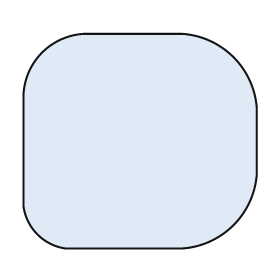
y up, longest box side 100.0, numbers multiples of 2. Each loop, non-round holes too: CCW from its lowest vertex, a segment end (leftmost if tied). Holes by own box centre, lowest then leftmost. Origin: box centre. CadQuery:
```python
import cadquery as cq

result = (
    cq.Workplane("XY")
    .moveTo(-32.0, -46.0)
    .lineTo(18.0, -46.0)
    .threePointArc((40.0, -36.0), (50.0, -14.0))
    .lineTo(50.0, 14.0)
    .threePointArc((40.0, 36.0), (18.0, 46.0))
    .lineTo(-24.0, 46.0)
    .threePointArc((-42.0, 38.0), (-50.0, 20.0))
    .lineTo(-50.0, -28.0)
    .threePointArc((-44.0, -40.0), (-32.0, -46.0))
    .close()
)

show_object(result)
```